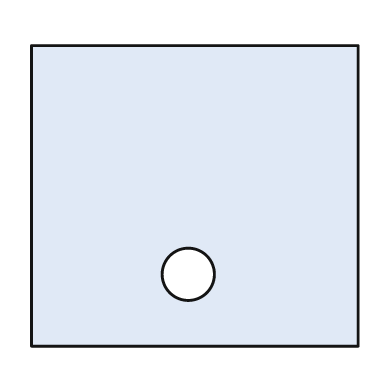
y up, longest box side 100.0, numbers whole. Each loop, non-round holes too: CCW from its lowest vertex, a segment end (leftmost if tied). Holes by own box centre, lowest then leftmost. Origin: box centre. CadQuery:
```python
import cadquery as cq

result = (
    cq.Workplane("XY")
    .moveTo(-50.0, -46.0)
    .lineTo(50.0, -46.0)
    .lineTo(50.0, 46.0)
    .lineTo(-50.0, 46.0)
    .close()
    .moveTo(-2.0, -24.0)
    .circle(8.0)
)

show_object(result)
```